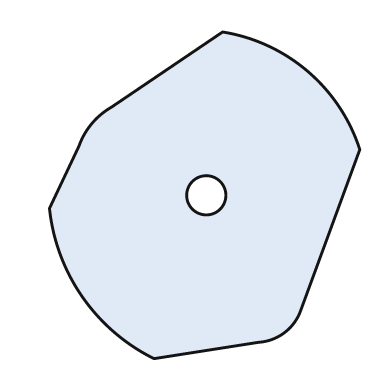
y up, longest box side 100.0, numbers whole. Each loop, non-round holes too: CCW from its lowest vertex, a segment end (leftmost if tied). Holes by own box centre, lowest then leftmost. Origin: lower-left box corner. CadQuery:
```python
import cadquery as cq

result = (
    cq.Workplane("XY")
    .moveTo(32.0, 0.0)
    .lineTo(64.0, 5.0)
    .threePointArc((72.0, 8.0), (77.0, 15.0))
    .lineTo(95.0, 64.0)
    .threePointArc((79.0, 88.0), (53.0, 100.0))
    .lineTo(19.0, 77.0)
    .threePointArc((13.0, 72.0), (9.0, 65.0))
    .lineTo(0.0, 46.0)
    .threePointArc((10.0, 19.0), (32.0, 0.0))
    .close()
    .moveTo(48.0, 50.0)
    .circle(6.0)
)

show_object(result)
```